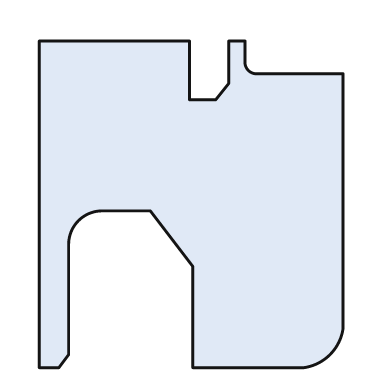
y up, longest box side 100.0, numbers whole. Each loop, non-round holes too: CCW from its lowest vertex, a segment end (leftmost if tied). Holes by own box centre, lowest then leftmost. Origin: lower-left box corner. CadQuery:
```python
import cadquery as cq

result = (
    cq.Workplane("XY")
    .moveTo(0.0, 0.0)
    .lineTo(6.0, 0.0)
    .lineTo(9.0, 4.0)
    .lineTo(9.0, 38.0)
    .threePointArc((12.0, 45.0), (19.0, 48.0))
    .lineTo(34.0, 48.0)
    .lineTo(47.0, 31.0)
    .lineTo(47.0, 0.0)
    .lineTo(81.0, 0.0)
    .threePointArc((89.0, 4.0), (93.0, 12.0))
    .lineTo(93.0, 90.0)
    .lineTo(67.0, 90.0)
    .threePointArc((64.0, 91.0), (63.0, 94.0))
    .lineTo(63.0, 100.0)
    .lineTo(58.0, 100.0)
    .lineTo(58.0, 87.0)
    .lineTo(54.0, 82.0)
    .lineTo(46.0, 82.0)
    .lineTo(46.0, 100.0)
    .lineTo(0.0, 100.0)
    .close()
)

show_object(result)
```